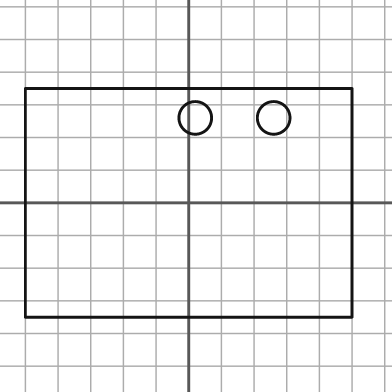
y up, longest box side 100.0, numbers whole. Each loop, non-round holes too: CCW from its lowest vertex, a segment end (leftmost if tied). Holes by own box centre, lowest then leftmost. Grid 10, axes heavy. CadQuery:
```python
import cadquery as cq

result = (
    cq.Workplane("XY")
    .moveTo(-50.0, -35.0)
    .lineTo(50.0, -35.0)
    .lineTo(50.0, 35.0)
    .lineTo(-50.0, 35.0)
    .close()
    .moveTo(2.0, 26.0)
    .circle(5.0)
    .moveTo(26.0, 26.0)
    .circle(5.0)
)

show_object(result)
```